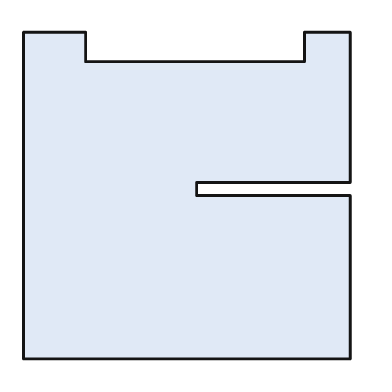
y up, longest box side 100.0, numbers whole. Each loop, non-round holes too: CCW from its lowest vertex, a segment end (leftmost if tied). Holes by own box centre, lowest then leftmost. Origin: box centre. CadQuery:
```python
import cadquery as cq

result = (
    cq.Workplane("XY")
    .moveTo(-50.0, -50.0)
    .lineTo(50.0, -50.0)
    .lineTo(50.0, 0.0)
    .lineTo(3.0, 0.0)
    .lineTo(3.0, 4.0)
    .lineTo(50.0, 4.0)
    .lineTo(50.0, 50.0)
    .lineTo(36.0, 50.0)
    .lineTo(36.0, 41.0)
    .lineTo(-31.0, 41.0)
    .lineTo(-31.0, 50.0)
    .lineTo(-50.0, 50.0)
    .close()
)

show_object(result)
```